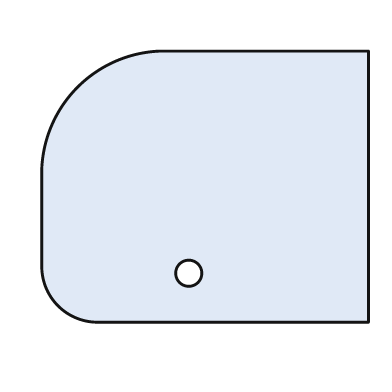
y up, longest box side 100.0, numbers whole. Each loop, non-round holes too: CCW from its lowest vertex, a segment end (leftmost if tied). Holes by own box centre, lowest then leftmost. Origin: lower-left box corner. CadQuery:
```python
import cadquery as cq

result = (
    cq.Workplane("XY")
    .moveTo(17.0, 0.0)
    .lineTo(100.0, 0.0)
    .lineTo(100.0, 83.0)
    .lineTo(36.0, 83.0)
    .threePointArc((11.0, 72.0), (0.0, 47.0))
    .lineTo(0.0, 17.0)
    .threePointArc((5.0, 5.0), (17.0, 0.0))
    .close()
    .moveTo(45.0, 15.0)
    .circle(4.0)
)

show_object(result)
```